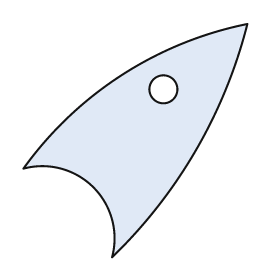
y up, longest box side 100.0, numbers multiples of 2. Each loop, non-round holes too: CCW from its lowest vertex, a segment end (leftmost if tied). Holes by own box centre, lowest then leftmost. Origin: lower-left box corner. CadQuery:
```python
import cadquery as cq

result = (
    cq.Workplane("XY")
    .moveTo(38.0, 0.0)
    .threePointArc((74.0, 46.0), (96.0, 100.0))
    .threePointArc((42.0, 78.0), (0.0, 38.0))
    .threePointArc((30.0, 30.0), (38.0, 0.0))
    .close()
    .moveTo(60.0, 72.0)
    .circle(6.0)
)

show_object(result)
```